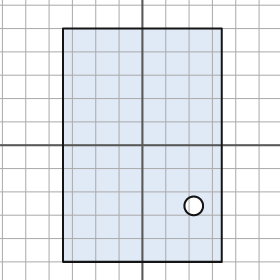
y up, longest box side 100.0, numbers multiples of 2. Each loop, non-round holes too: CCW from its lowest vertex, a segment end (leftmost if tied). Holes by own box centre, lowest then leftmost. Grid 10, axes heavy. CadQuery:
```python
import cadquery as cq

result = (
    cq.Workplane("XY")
    .moveTo(-34.0, -50.0)
    .lineTo(34.0, -50.0)
    .lineTo(34.0, 50.0)
    .lineTo(-34.0, 50.0)
    .close()
    .moveTo(22.0, -26.0)
    .circle(4.0)
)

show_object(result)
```